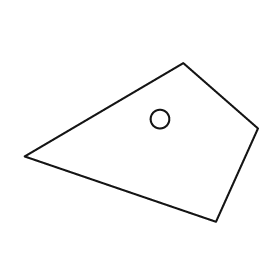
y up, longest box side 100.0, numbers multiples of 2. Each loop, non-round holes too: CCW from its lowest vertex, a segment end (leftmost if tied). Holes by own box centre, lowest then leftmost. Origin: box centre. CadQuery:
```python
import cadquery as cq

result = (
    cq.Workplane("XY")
    .moveTo(32.0, -34.0)
    .lineTo(50.0, 6.0)
    .lineTo(18.0, 34.0)
    .lineTo(-50.0, -6.0)
    .close()
    .moveTo(8.0, 10.0)
    .circle(4.0)
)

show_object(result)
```